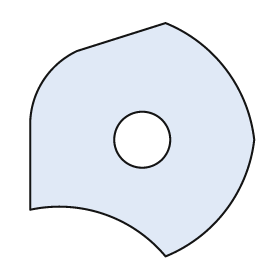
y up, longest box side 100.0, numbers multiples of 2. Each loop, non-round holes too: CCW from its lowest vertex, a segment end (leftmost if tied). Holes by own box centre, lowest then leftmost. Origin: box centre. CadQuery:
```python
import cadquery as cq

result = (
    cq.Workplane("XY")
    .moveTo(10.0, -50.0)
    .threePointArc((36.0, -30.0), (48.0, 0.0))
    .threePointArc((36.0, 30.0), (10.0, 50.0))
    .lineTo(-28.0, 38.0)
    .threePointArc((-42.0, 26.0), (-48.0, 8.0))
    .lineTo(-48.0, -30.0)
    .threePointArc((-16.0, -32.0), (10.0, -50.0))
    .close()
    .moveTo(0.0, 0.0)
    .circle(12.0)
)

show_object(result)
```